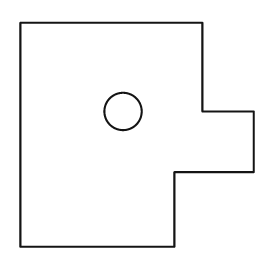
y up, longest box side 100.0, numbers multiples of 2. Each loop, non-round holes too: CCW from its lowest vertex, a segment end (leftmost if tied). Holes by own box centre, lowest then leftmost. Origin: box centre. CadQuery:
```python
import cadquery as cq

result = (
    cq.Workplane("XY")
    .moveTo(-50.0, -48.0)
    .lineTo(16.0, -48.0)
    .lineTo(16.0, -16.0)
    .lineTo(50.0, -16.0)
    .lineTo(50.0, 10.0)
    .lineTo(28.0, 10.0)
    .lineTo(28.0, 48.0)
    .lineTo(-50.0, 48.0)
    .close()
    .moveTo(-6.0, 10.0)
    .circle(8.0)
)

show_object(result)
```